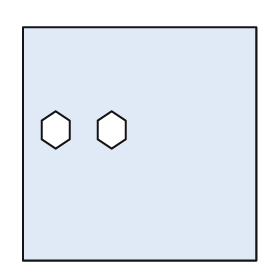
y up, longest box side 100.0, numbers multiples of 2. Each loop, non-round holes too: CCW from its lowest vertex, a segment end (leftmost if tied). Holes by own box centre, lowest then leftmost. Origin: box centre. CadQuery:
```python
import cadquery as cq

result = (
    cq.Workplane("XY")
    .moveTo(-50.0, -50.0)
    .lineTo(50.0, -50.0)
    .lineTo(50.0, 50.0)
    .lineTo(-50.0, 50.0)
    .close()
    .moveTo(-36.0, -2.0)
    .lineTo(-30.0, 2.0)
    .lineTo(-30.0, 10.0)
    .lineTo(-36.0, 14.0)
    .lineTo(-42.0, 10.0)
    .lineTo(-42.0, 2.0)
    .close()
    .moveTo(-12.0, -2.0)
    .lineTo(-6.0, 2.0)
    .lineTo(-6.0, 10.0)
    .lineTo(-12.0, 14.0)
    .lineTo(-18.0, 10.0)
    .lineTo(-18.0, 2.0)
    .close()
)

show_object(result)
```